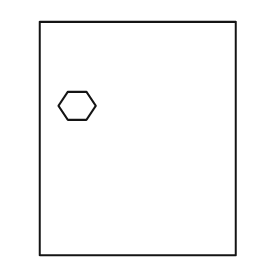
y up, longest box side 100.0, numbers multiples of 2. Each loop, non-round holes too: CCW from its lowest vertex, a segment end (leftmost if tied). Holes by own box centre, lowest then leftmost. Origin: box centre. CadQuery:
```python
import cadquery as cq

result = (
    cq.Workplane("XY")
    .moveTo(-42.0, -50.0)
    .lineTo(42.0, -50.0)
    .lineTo(42.0, 50.0)
    .lineTo(-42.0, 50.0)
    .close()
    .moveTo(-30.0, 8.0)
    .lineTo(-22.0, 8.0)
    .lineTo(-18.0, 14.0)
    .lineTo(-22.0, 20.0)
    .lineTo(-30.0, 20.0)
    .lineTo(-34.0, 14.0)
    .close()
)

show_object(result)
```